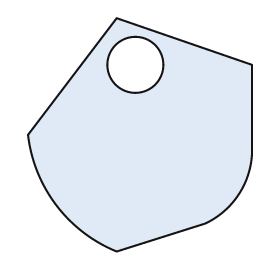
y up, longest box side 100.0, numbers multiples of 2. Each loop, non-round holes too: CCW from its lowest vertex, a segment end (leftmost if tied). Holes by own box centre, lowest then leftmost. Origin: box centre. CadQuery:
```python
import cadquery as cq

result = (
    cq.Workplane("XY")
    .moveTo(-10.0, -50.0)
    .lineTo(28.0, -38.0)
    .threePointArc((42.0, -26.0), (48.0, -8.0))
    .lineTo(48.0, 30.0)
    .lineTo(-10.0, 50.0)
    .lineTo(-48.0, 0.0)
    .threePointArc((-36.0, -30.0), (-10.0, -50.0))
    .close()
    .moveTo(-2.0, 30.0)
    .circle(12.0)
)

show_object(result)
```